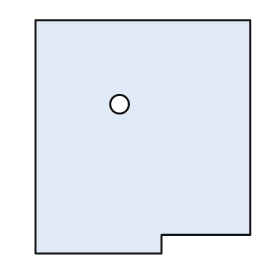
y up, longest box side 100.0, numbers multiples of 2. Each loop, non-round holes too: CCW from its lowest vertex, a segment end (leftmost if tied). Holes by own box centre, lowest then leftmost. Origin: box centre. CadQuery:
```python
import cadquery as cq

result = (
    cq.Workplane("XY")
    .moveTo(-46.0, -50.0)
    .lineTo(8.0, -50.0)
    .lineTo(8.0, -42.0)
    .lineTo(46.0, -42.0)
    .lineTo(46.0, 50.0)
    .lineTo(-46.0, 50.0)
    .close()
    .moveTo(-10.0, 14.0)
    .circle(4.0)
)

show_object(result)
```